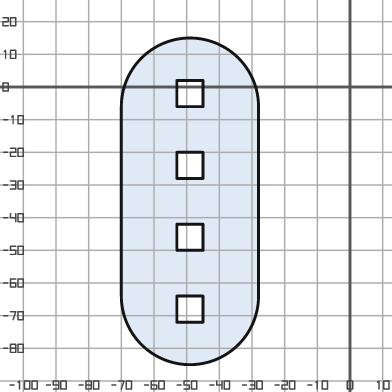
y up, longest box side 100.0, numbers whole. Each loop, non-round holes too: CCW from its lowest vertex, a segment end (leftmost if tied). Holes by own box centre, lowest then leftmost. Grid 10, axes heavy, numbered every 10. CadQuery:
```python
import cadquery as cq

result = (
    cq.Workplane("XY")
    .moveTo(-70.0, -64.0)
    .threePointArc((-49.0, -85.0), (-28.0, -64.0))
    .lineTo(-28.0, -6.0)
    .threePointArc((-49.0, 15.0), (-70.0, -6.0))
    .close()
    .moveTo(-53.0, -72.0)
    .lineTo(-45.0, -72.0)
    .lineTo(-45.0, -64.0)
    .lineTo(-53.0, -64.0)
    .close()
    .moveTo(-53.0, -50.0)
    .lineTo(-45.0, -50.0)
    .lineTo(-45.0, -42.0)
    .lineTo(-53.0, -42.0)
    .close()
    .moveTo(-53.0, -28.0)
    .lineTo(-45.0, -28.0)
    .lineTo(-45.0, -20.0)
    .lineTo(-53.0, -20.0)
    .close()
    .moveTo(-53.0, -6.0)
    .lineTo(-45.0, -6.0)
    .lineTo(-45.0, 2.0)
    .lineTo(-53.0, 2.0)
    .close()
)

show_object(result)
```